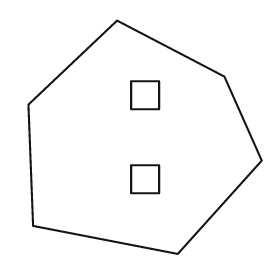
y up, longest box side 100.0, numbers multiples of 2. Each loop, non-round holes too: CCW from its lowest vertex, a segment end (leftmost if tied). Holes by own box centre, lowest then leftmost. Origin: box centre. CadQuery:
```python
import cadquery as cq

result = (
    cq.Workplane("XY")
    .moveTo(14.0, -50.0)
    .lineTo(50.0, -10.0)
    .lineTo(34.0, 26.0)
    .lineTo(-12.0, 50.0)
    .lineTo(-50.0, 14.0)
    .lineTo(-48.0, -38.0)
    .close()
    .moveTo(-6.0, -24.0)
    .lineTo(6.0, -24.0)
    .lineTo(6.0, -12.0)
    .lineTo(-6.0, -12.0)
    .close()
    .moveTo(-6.0, 12.0)
    .lineTo(6.0, 12.0)
    .lineTo(6.0, 24.0)
    .lineTo(-6.0, 24.0)
    .close()
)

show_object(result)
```